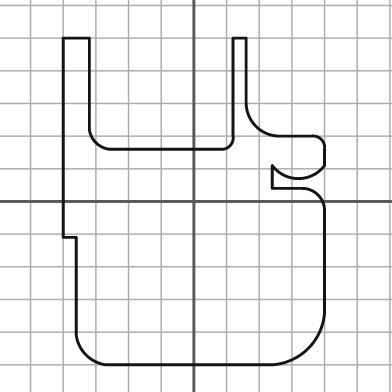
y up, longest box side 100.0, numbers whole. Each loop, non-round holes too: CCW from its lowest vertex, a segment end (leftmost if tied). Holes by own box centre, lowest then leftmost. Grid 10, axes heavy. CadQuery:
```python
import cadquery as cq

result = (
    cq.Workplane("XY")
    .moveTo(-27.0, -50.0)
    .lineTo(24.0, -50.0)
    .threePointArc((35.0, -45.0), (40.0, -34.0))
    .lineTo(40.0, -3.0)
    .threePointArc((38.0, 2.0), (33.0, 4.0))
    .lineTo(24.0, 4.0)
    .lineTo(24.0, 11.0)
    .threePointArc((32.0, 7.0), (40.0, 11.0))
    .lineTo(40.0, 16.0)
    .threePointArc((39.0, 19.0), (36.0, 20.0))
    .lineTo(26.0, 20.0)
    .threePointArc((19.0, 23.0), (16.0, 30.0))
    .lineTo(16.0, 50.0)
    .lineTo(12.0, 50.0)
    .lineTo(12.0, 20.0)
    .threePointArc((11.0, 17.0), (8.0, 16.0))
    .lineTo(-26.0, 16.0)
    .threePointArc((-30.0, 18.0), (-32.0, 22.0))
    .lineTo(-32.0, 50.0)
    .lineTo(-40.0, 50.0)
    .lineTo(-40.0, -11.0)
    .lineTo(-36.0, -11.0)
    .lineTo(-36.0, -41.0)
    .threePointArc((-33.0, -47.0), (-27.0, -50.0))
    .close()
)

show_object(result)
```